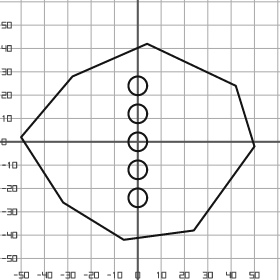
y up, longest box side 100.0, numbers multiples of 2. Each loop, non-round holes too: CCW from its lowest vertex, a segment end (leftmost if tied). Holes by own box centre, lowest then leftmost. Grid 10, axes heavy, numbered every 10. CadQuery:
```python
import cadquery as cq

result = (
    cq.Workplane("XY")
    .moveTo(-6.0, -42.0)
    .lineTo(24.0, -38.0)
    .lineTo(50.0, -2.0)
    .lineTo(42.0, 24.0)
    .lineTo(4.0, 42.0)
    .lineTo(-28.0, 28.0)
    .lineTo(-50.0, 2.0)
    .lineTo(-32.0, -26.0)
    .close()
    .moveTo(0.0, -24.0)
    .circle(4.0)
    .moveTo(0.0, -12.0)
    .circle(4.0)
    .moveTo(0.0, 0.0)
    .circle(4.0)
    .moveTo(0.0, 12.0)
    .circle(4.0)
    .moveTo(0.0, 24.0)
    .circle(4.0)
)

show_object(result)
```